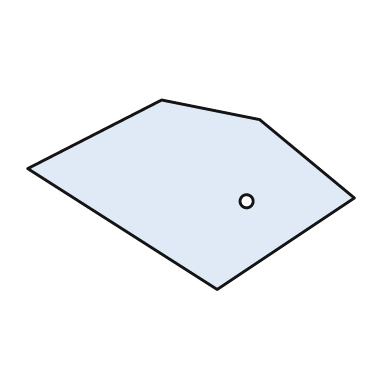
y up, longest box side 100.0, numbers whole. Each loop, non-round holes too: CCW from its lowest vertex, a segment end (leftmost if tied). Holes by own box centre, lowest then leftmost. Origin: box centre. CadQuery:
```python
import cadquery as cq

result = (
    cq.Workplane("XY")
    .moveTo(8.0, -29.0)
    .lineTo(50.0, -1.0)
    .lineTo(21.0, 23.0)
    .lineTo(-9.0, 29.0)
    .lineTo(-50.0, 8.0)
    .close()
    .moveTo(17.0, -2.0)
    .circle(2.0)
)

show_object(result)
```